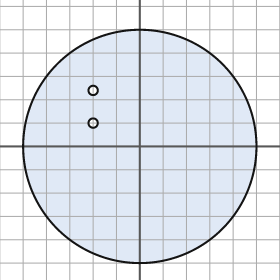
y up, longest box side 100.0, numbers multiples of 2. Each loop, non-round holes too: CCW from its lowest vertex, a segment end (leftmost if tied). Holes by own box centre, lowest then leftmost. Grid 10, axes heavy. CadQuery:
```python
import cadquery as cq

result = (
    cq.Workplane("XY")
    .moveTo(0.0, 0.0)
    .circle(50.0)
    .moveTo(-20.0, 10.0)
    .circle(2.0)
    .moveTo(-20.0, 24.0)
    .circle(2.0)
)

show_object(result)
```